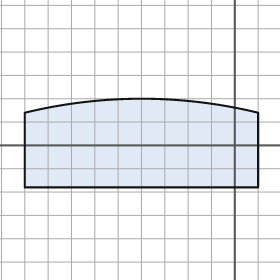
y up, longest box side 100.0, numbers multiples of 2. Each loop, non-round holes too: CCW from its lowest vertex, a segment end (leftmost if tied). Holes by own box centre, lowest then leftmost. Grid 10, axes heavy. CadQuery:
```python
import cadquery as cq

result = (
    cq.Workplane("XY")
    .moveTo(-90.0, -18.0)
    .lineTo(10.0, -18.0)
    .lineTo(10.0, 14.0)
    .threePointArc((-40.0, 20.0), (-90.0, 14.0))
    .close()
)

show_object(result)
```